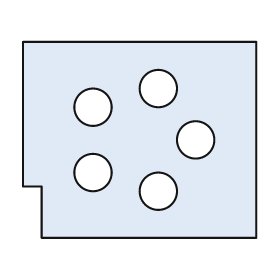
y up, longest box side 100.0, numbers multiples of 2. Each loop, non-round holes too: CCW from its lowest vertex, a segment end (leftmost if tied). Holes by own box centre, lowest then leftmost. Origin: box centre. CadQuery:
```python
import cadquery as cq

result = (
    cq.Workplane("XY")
    .moveTo(-42.0, -42.0)
    .lineTo(50.0, -42.0)
    .lineTo(50.0, 42.0)
    .lineTo(-50.0, 42.0)
    .lineTo(-50.0, -20.0)
    .lineTo(-42.0, -20.0)
    .close()
    .moveTo(8.0, -22.0)
    .circle(8.0)
    .moveTo(-20.0, -14.0)
    .circle(8.0)
    .moveTo(24.0, 0.0)
    .circle(8.0)
    .moveTo(-20.0, 14.0)
    .circle(8.0)
    .moveTo(8.0, 22.0)
    .circle(8.0)
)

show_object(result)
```